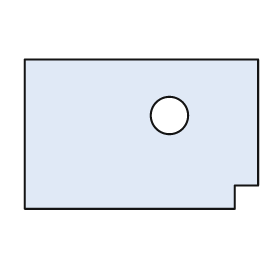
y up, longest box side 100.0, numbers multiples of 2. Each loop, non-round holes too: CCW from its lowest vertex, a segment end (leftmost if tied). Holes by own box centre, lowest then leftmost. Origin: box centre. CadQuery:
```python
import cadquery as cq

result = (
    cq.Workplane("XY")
    .moveTo(-50.0, -32.0)
    .lineTo(40.0, -32.0)
    .lineTo(40.0, -22.0)
    .lineTo(50.0, -22.0)
    .lineTo(50.0, 32.0)
    .lineTo(-50.0, 32.0)
    .close()
    .moveTo(12.0, 8.0)
    .circle(8.0)
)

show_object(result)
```